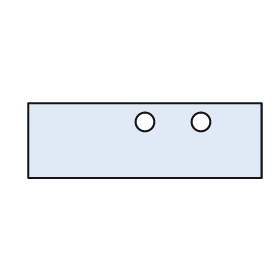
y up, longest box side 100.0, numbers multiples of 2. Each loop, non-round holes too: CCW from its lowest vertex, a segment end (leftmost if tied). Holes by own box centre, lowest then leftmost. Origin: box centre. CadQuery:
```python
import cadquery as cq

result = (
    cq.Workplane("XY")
    .moveTo(-50.0, -16.0)
    .lineTo(50.0, -16.0)
    .lineTo(50.0, 16.0)
    .lineTo(-50.0, 16.0)
    .close()
    .moveTo(0.0, 8.0)
    .circle(4.0)
    .moveTo(24.0, 8.0)
    .circle(4.0)
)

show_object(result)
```